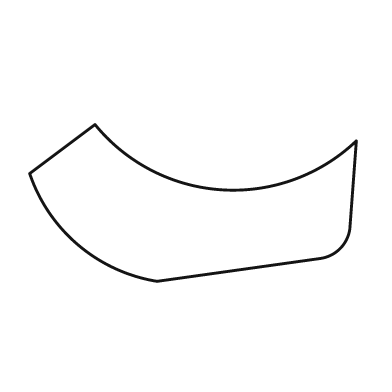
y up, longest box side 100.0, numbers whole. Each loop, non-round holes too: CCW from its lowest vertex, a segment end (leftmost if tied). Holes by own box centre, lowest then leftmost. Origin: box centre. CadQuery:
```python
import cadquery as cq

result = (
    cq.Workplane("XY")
    .moveTo(-11.0, -24.0)
    .lineTo(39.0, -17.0)
    .threePointArc((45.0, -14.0), (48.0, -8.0))
    .lineTo(50.0, 19.0)
    .threePointArc((9.0, 4.0), (-30.0, 24.0))
    .lineTo(-50.0, 9.0)
    .threePointArc((-35.0, -13.0), (-11.0, -24.0))
    .close()
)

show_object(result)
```